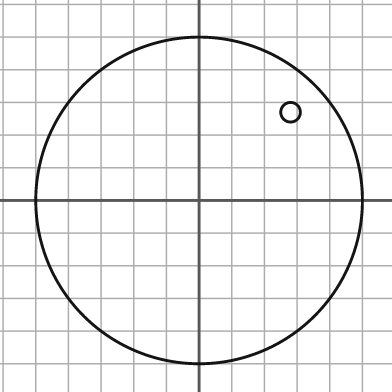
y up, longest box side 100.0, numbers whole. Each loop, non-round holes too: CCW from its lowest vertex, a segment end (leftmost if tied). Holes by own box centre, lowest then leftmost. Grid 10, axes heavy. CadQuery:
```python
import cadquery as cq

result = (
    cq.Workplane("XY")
    .moveTo(0.0, 0.0)
    .circle(50.0)
    .moveTo(28.0, 27.0)
    .circle(3.0)
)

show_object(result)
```